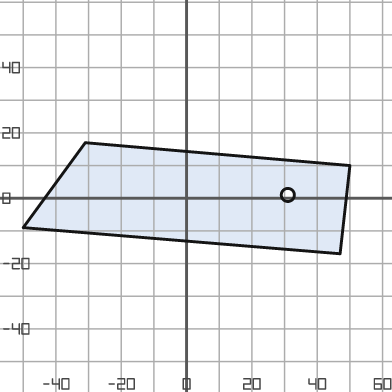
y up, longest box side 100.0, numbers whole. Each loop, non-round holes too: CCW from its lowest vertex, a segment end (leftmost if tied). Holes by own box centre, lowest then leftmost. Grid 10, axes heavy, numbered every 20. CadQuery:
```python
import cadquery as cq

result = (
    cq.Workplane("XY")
    .moveTo(47.0, -17.0)
    .lineTo(50.0, 10.0)
    .lineTo(-31.0, 17.0)
    .lineTo(-50.0, -9.0)
    .close()
    .moveTo(31.0, 1.0)
    .circle(2.0)
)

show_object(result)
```